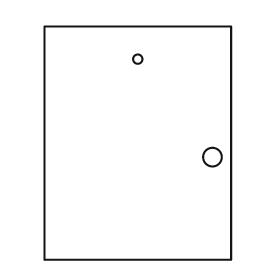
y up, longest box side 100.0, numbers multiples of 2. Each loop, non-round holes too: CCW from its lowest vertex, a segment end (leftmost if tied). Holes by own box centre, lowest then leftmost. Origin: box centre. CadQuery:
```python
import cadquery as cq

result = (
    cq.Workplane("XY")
    .moveTo(-40.0, -50.0)
    .lineTo(40.0, -50.0)
    .lineTo(40.0, 50.0)
    .lineTo(-40.0, 50.0)
    .close()
    .moveTo(32.0, -6.0)
    .circle(4.0)
    .moveTo(0.0, 36.0)
    .circle(2.0)
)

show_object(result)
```